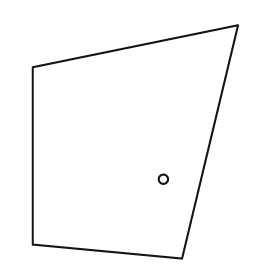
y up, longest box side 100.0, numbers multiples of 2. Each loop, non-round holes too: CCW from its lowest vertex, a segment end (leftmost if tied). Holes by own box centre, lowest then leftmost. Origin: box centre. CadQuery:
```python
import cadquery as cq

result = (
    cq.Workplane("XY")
    .moveTo(20.0, -50.0)
    .lineTo(44.0, 50.0)
    .lineTo(-44.0, 32.0)
    .lineTo(-44.0, -44.0)
    .close()
    .moveTo(12.0, -16.0)
    .circle(2.0)
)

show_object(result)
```